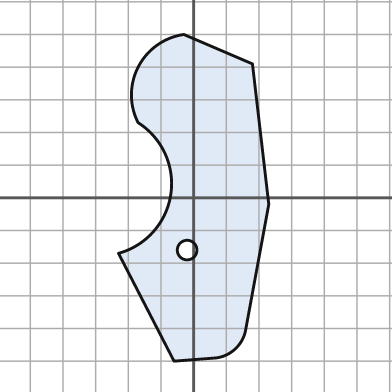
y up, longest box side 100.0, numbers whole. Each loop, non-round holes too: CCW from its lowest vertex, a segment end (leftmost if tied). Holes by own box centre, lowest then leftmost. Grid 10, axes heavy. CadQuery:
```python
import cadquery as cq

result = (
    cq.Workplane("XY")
    .moveTo(-6.0, -50.0)
    .lineTo(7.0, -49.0)
    .threePointArc((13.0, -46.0), (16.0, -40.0))
    .lineTo(23.0, -2.0)
    .lineTo(18.0, 41.0)
    .lineTo(-3.0, 50.0)
    .threePointArc((-17.0, 40.0), (-17.0, 23.0))
    .threePointArc((-7.0, 1.0), (-23.0, -17.0))
    .close()
    .moveTo(-2.0, -16.0)
    .circle(3.0)
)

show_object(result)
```